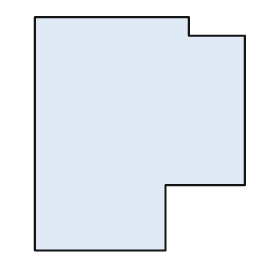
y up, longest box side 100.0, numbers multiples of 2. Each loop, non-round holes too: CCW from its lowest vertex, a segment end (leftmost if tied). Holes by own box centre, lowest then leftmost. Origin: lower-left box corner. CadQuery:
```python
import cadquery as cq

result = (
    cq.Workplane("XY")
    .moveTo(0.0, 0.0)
    .lineTo(56.0, 0.0)
    .lineTo(56.0, 28.0)
    .lineTo(90.0, 28.0)
    .lineTo(90.0, 92.0)
    .lineTo(66.0, 92.0)
    .lineTo(66.0, 100.0)
    .lineTo(0.0, 100.0)
    .close()
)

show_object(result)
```